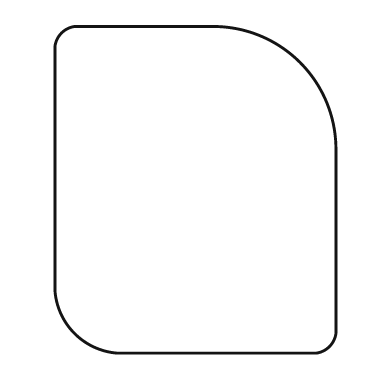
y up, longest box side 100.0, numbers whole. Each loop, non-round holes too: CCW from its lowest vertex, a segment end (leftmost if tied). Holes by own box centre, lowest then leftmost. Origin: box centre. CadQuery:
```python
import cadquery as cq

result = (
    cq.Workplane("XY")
    .moveTo(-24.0, -50.0)
    .lineTo(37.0, -50.0)
    .threePointArc((41.0, -48.0), (43.0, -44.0))
    .lineTo(43.0, 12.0)
    .threePointArc((32.0, 39.0), (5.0, 50.0))
    .lineTo(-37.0, 50.0)
    .threePointArc((-41.0, 48.0), (-43.0, 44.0))
    .lineTo(-43.0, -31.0)
    .threePointArc((-37.0, -44.0), (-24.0, -50.0))
    .close()
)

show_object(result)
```